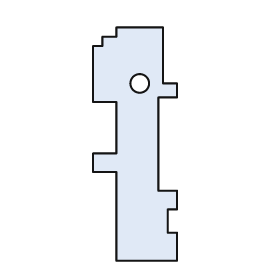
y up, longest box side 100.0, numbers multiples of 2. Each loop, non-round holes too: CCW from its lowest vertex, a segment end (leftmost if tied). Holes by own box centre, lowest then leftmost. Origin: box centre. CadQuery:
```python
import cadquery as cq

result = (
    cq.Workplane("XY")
    .moveTo(-8.0, -50.0)
    .lineTo(18.0, -50.0)
    .lineTo(18.0, -38.0)
    .lineTo(14.0, -38.0)
    .lineTo(14.0, -28.0)
    .lineTo(18.0, -28.0)
    .lineTo(18.0, -20.0)
    .lineTo(10.0, -20.0)
    .lineTo(10.0, 20.0)
    .lineTo(18.0, 20.0)
    .lineTo(18.0, 26.0)
    .lineTo(12.0, 26.0)
    .lineTo(12.0, 50.0)
    .lineTo(-8.0, 50.0)
    .lineTo(-8.0, 46.0)
    .lineTo(-14.0, 46.0)
    .lineTo(-14.0, 42.0)
    .lineTo(-18.0, 42.0)
    .lineTo(-18.0, 18.0)
    .lineTo(-8.0, 18.0)
    .lineTo(-8.0, -4.0)
    .lineTo(-18.0, -4.0)
    .lineTo(-18.0, -12.0)
    .lineTo(-8.0, -12.0)
    .close()
    .moveTo(2.0, 26.0)
    .circle(4.0)
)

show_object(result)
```